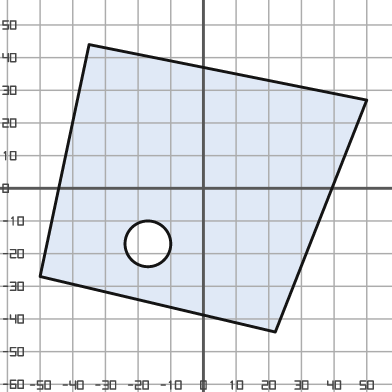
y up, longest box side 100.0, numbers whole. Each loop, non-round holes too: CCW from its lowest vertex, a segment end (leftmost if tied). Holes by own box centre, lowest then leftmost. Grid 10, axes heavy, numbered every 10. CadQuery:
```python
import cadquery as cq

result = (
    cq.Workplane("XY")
    .moveTo(22.0, -44.0)
    .lineTo(50.0, 27.0)
    .lineTo(-35.0, 44.0)
    .lineTo(-50.0, -27.0)
    .close()
    .moveTo(-17.0, -17.0)
    .circle(7.0)
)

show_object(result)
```